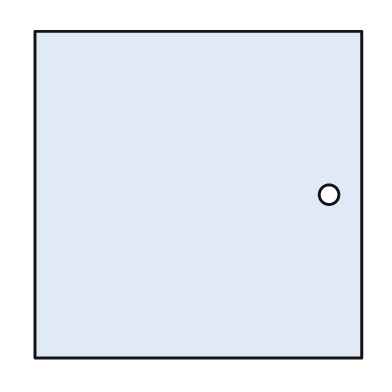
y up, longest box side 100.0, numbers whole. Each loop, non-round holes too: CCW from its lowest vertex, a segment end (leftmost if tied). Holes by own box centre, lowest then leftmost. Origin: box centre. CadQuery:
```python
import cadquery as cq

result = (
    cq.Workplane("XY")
    .moveTo(-50.0, -50.0)
    .lineTo(50.0, -50.0)
    .lineTo(50.0, 50.0)
    .lineTo(-50.0, 50.0)
    .close()
    .moveTo(40.0, 0.0)
    .circle(3.0)
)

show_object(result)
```